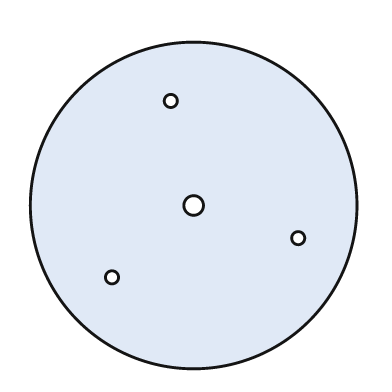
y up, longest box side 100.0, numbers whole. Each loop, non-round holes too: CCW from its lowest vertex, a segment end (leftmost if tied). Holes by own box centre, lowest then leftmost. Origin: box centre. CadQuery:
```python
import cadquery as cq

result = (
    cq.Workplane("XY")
    .moveTo(0.0, 0.0)
    .circle(50.0)
    .moveTo(-25.0, -22.0)
    .circle(2.0)
    .moveTo(32.0, -10.0)
    .circle(2.0)
    .moveTo(0.0, 0.0)
    .circle(3.0)
    .moveTo(-7.0, 32.0)
    .circle(2.0)
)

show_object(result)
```